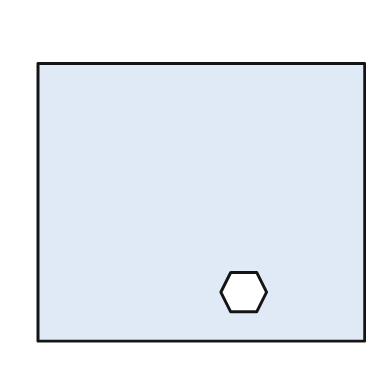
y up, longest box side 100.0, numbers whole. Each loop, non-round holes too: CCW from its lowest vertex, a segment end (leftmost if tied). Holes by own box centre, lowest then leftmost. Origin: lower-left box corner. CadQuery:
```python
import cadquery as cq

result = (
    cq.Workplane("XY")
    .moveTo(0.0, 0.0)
    .lineTo(100.0, 0.0)
    .lineTo(100.0, 85.0)
    .lineTo(0.0, 85.0)
    .close()
    .moveTo(59.0, 9.0)
    .lineTo(67.0, 9.0)
    .lineTo(70.0, 15.0)
    .lineTo(67.0, 21.0)
    .lineTo(59.0, 21.0)
    .lineTo(56.0, 15.0)
    .close()
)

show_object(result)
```